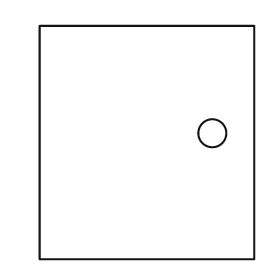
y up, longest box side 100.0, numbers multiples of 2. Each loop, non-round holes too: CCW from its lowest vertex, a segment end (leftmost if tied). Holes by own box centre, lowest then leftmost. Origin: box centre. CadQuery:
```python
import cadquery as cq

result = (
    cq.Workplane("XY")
    .moveTo(-46.0, -50.0)
    .lineTo(46.0, -50.0)
    .lineTo(46.0, 50.0)
    .lineTo(-46.0, 50.0)
    .close()
    .moveTo(28.0, 4.0)
    .circle(6.0)
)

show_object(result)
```